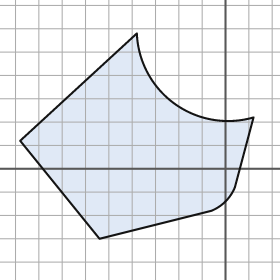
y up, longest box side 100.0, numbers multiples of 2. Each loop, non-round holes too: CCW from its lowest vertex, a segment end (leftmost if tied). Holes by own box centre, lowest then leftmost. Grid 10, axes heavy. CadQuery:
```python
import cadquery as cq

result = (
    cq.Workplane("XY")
    .moveTo(-54.0, -30.0)
    .lineTo(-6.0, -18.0)
    .threePointArc((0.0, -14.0), (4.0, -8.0))
    .lineTo(12.0, 22.0)
    .threePointArc((-22.0, 28.0), (-38.0, 58.0))
    .lineTo(-88.0, 12.0)
    .close()
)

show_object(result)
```